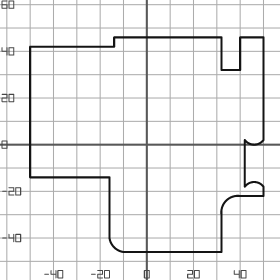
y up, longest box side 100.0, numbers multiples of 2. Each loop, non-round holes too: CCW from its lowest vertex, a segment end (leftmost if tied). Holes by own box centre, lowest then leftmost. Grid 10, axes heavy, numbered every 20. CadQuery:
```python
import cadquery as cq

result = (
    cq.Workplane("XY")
    .moveTo(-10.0, -46.0)
    .lineTo(32.0, -46.0)
    .lineTo(32.0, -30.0)
    .threePointArc((34.0, -24.0), (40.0, -22.0))
    .lineTo(50.0, -22.0)
    .lineTo(50.0, -18.0)
    .threePointArc((46.0, -16.0), (42.0, -18.0))
    .lineTo(42.0, 2.0)
    .threePointArc((46.0, 0.0), (50.0, 2.0))
    .lineTo(50.0, 46.0)
    .lineTo(40.0, 46.0)
    .lineTo(40.0, 32.0)
    .lineTo(32.0, 32.0)
    .lineTo(32.0, 46.0)
    .lineTo(-14.0, 46.0)
    .lineTo(-14.0, 42.0)
    .lineTo(-50.0, 42.0)
    .lineTo(-50.0, -14.0)
    .lineTo(-16.0, -14.0)
    .lineTo(-16.0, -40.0)
    .threePointArc((-14.0, -44.0), (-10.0, -46.0))
    .close()
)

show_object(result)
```